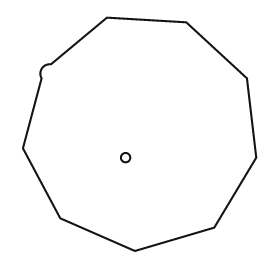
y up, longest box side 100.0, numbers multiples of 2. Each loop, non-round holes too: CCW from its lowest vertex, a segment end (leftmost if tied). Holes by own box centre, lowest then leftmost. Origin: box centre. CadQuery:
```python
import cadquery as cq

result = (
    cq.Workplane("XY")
    .moveTo(-2.0, -50.0)
    .lineTo(32.0, -40.0)
    .lineTo(50.0, -10.0)
    .lineTo(46.0, 24.0)
    .lineTo(20.0, 48.0)
    .lineTo(-14.0, 50.0)
    .lineTo(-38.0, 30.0)
    .threePointArc((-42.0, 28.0), (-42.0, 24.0))
    .lineTo(-50.0, -6.0)
    .lineTo(-34.0, -36.0)
    .close()
    .moveTo(-6.0, -10.0)
    .circle(2.0)
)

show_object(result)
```